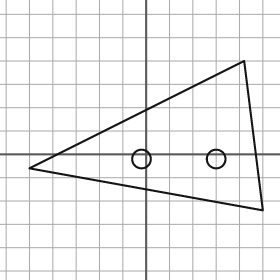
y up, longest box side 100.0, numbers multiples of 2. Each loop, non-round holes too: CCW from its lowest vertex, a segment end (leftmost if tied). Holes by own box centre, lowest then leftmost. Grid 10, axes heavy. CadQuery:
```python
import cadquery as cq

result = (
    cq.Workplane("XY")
    .moveTo(50.0, -24.0)
    .lineTo(42.0, 40.0)
    .lineTo(-50.0, -6.0)
    .close()
    .moveTo(-2.0, -2.0)
    .circle(4.0)
    .moveTo(30.0, -2.0)
    .circle(4.0)
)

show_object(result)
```